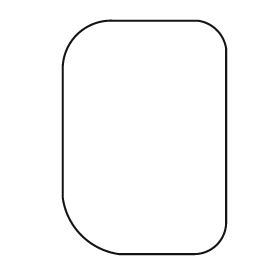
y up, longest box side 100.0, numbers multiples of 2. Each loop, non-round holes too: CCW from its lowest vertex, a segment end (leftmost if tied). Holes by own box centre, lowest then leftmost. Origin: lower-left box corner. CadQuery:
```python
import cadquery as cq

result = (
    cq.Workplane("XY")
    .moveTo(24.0, 0.0)
    .lineTo(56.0, 0.0)
    .threePointArc((66.0, 4.0), (70.0, 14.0))
    .lineTo(70.0, 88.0)
    .threePointArc((66.0, 96.0), (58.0, 100.0))
    .lineTo(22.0, 100.0)
    .threePointArc((6.0, 94.0), (0.0, 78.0))
    .lineTo(0.0, 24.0)
    .threePointArc((8.0, 8.0), (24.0, 0.0))
    .close()
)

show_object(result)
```